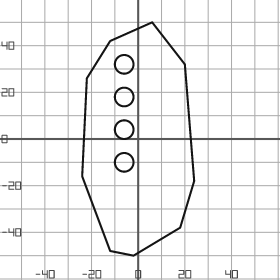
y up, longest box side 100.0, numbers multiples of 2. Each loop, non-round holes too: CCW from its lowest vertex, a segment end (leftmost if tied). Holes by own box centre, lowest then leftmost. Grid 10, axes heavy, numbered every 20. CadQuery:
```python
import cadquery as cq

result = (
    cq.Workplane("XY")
    .moveTo(-2.0, -50.0)
    .lineTo(18.0, -38.0)
    .lineTo(24.0, -18.0)
    .lineTo(20.0, 32.0)
    .lineTo(6.0, 50.0)
    .lineTo(-12.0, 42.0)
    .lineTo(-22.0, 26.0)
    .lineTo(-24.0, -16.0)
    .lineTo(-12.0, -48.0)
    .close()
    .moveTo(-6.0, -10.0)
    .circle(4.0)
    .moveTo(-6.0, 4.0)
    .circle(4.0)
    .moveTo(-6.0, 18.0)
    .circle(4.0)
    .moveTo(-6.0, 32.0)
    .circle(4.0)
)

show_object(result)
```